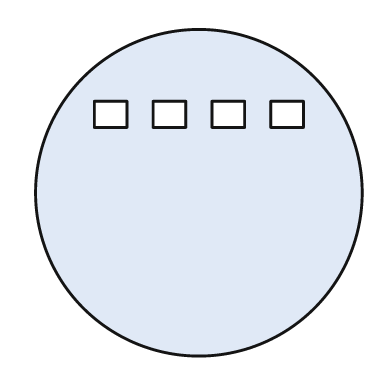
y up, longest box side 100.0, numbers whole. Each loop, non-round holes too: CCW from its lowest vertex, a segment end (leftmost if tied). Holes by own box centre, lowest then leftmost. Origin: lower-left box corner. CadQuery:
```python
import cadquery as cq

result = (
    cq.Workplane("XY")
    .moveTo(50.0, 50.0)
    .circle(50.0)
    .moveTo(18.0, 70.0)
    .lineTo(28.0, 70.0)
    .lineTo(28.0, 78.0)
    .lineTo(18.0, 78.0)
    .close()
    .moveTo(36.0, 70.0)
    .lineTo(46.0, 70.0)
    .lineTo(46.0, 78.0)
    .lineTo(36.0, 78.0)
    .close()
    .moveTo(54.0, 70.0)
    .lineTo(64.0, 70.0)
    .lineTo(64.0, 78.0)
    .lineTo(54.0, 78.0)
    .close()
    .moveTo(72.0, 70.0)
    .lineTo(82.0, 70.0)
    .lineTo(82.0, 78.0)
    .lineTo(72.0, 78.0)
    .close()
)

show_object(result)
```